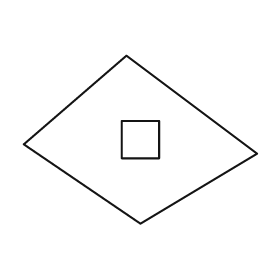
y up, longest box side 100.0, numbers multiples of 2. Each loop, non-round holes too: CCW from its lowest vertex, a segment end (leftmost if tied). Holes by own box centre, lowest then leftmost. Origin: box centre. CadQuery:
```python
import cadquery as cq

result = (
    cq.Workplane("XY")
    .moveTo(0.0, -36.0)
    .lineTo(50.0, -6.0)
    .lineTo(-6.0, 36.0)
    .lineTo(-50.0, -2.0)
    .close()
    .moveTo(-8.0, -8.0)
    .lineTo(8.0, -8.0)
    .lineTo(8.0, 8.0)
    .lineTo(-8.0, 8.0)
    .close()
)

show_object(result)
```